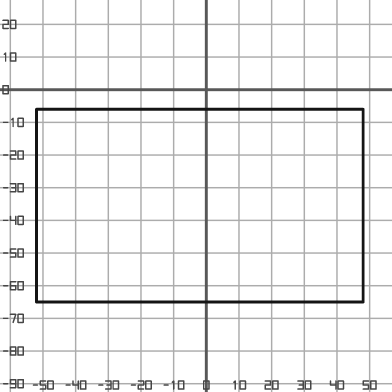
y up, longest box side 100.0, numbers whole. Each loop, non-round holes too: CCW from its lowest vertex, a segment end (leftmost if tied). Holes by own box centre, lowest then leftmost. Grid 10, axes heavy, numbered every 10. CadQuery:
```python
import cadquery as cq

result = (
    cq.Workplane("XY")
    .moveTo(-52.0, -65.0)
    .lineTo(48.0, -65.0)
    .lineTo(48.0, -6.0)
    .lineTo(-52.0, -6.0)
    .close()
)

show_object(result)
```